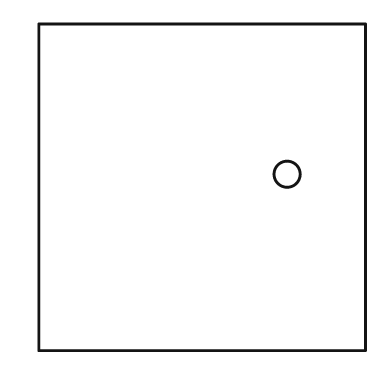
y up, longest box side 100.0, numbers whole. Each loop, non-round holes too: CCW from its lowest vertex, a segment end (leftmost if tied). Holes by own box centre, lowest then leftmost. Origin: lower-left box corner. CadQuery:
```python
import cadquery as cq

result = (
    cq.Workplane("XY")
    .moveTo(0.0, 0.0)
    .lineTo(100.0, 0.0)
    .lineTo(100.0, 100.0)
    .lineTo(0.0, 100.0)
    .close()
    .moveTo(76.0, 54.0)
    .circle(4.0)
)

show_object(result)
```